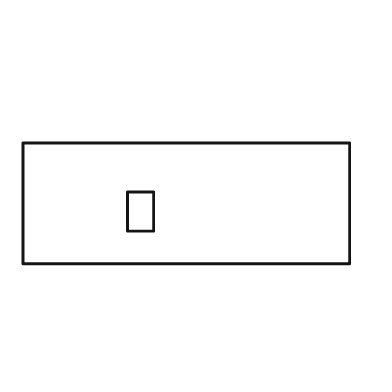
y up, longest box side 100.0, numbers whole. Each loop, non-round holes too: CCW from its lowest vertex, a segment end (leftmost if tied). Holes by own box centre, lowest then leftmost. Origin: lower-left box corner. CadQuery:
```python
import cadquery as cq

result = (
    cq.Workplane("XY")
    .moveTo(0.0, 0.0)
    .lineTo(100.0, 0.0)
    .lineTo(100.0, 37.0)
    .lineTo(0.0, 37.0)
    .close()
    .moveTo(32.0, 10.0)
    .lineTo(40.0, 10.0)
    .lineTo(40.0, 22.0)
    .lineTo(32.0, 22.0)
    .close()
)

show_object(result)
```